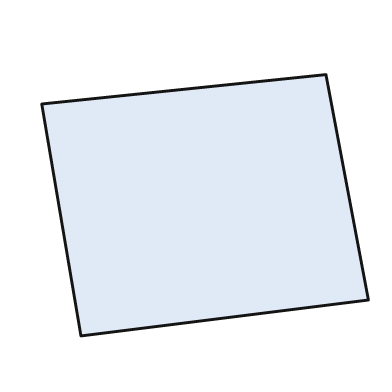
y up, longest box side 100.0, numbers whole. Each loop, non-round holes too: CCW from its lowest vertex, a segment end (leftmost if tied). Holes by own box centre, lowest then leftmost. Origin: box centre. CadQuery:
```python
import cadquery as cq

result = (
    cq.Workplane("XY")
    .moveTo(-38.0, -40.0)
    .lineTo(50.0, -29.0)
    .lineTo(37.0, 40.0)
    .lineTo(-50.0, 31.0)
    .close()
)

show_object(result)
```